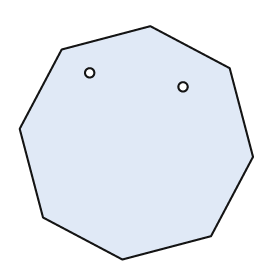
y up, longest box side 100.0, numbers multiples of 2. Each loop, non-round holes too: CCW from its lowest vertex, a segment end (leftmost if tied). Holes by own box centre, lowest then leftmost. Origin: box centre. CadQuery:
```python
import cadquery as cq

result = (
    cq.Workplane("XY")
    .moveTo(-6.0, -50.0)
    .lineTo(32.0, -40.0)
    .lineTo(50.0, -6.0)
    .lineTo(40.0, 32.0)
    .lineTo(6.0, 50.0)
    .lineTo(-32.0, 40.0)
    .lineTo(-50.0, 6.0)
    .lineTo(-40.0, -32.0)
    .close()
    .moveTo(20.0, 24.0)
    .circle(2.0)
    .moveTo(-20.0, 30.0)
    .circle(2.0)
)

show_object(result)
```